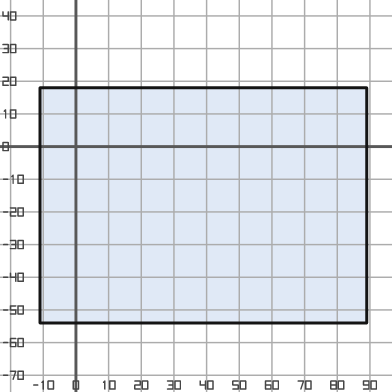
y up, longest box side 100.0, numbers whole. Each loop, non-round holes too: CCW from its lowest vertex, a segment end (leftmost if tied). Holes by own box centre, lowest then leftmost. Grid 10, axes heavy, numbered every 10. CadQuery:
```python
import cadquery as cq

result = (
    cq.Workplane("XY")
    .moveTo(-11.0, -54.0)
    .lineTo(89.0, -54.0)
    .lineTo(89.0, 18.0)
    .lineTo(-11.0, 18.0)
    .close()
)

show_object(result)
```